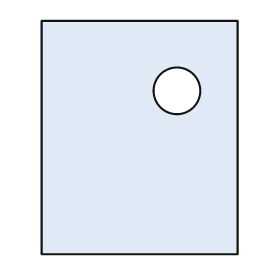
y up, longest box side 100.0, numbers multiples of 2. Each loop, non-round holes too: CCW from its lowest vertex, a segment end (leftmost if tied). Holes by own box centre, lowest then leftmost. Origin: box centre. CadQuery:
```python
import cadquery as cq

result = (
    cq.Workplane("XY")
    .moveTo(-42.0, -50.0)
    .lineTo(42.0, -50.0)
    .lineTo(42.0, 50.0)
    .lineTo(-42.0, 50.0)
    .close()
    .moveTo(16.0, 20.0)
    .circle(10.0)
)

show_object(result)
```